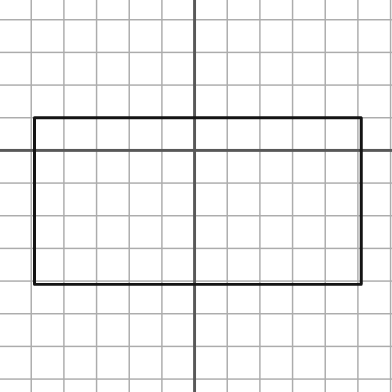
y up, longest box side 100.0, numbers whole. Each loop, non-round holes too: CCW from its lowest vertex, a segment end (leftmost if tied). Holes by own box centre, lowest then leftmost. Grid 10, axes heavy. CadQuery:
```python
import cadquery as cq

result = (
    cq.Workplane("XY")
    .moveTo(-49.0, -41.0)
    .lineTo(51.0, -41.0)
    .lineTo(51.0, 10.0)
    .lineTo(-49.0, 10.0)
    .close()
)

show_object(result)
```